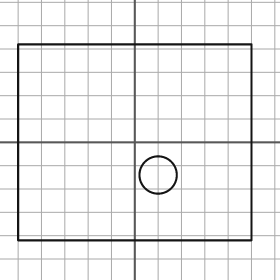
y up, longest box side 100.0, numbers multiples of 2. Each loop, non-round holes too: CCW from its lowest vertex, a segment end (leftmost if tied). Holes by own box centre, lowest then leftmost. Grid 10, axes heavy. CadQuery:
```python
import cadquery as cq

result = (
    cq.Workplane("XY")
    .moveTo(-50.0, -42.0)
    .lineTo(50.0, -42.0)
    .lineTo(50.0, 42.0)
    .lineTo(-50.0, 42.0)
    .close()
    .moveTo(10.0, -14.0)
    .circle(8.0)
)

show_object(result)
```